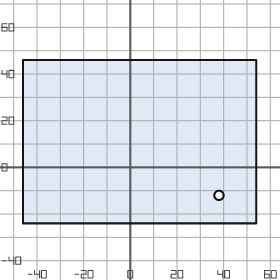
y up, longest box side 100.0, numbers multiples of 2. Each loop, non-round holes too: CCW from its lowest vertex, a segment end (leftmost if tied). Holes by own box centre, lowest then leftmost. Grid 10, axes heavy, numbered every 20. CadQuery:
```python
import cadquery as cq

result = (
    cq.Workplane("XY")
    .moveTo(-46.0, -24.0)
    .lineTo(54.0, -24.0)
    .lineTo(54.0, 46.0)
    .lineTo(-46.0, 46.0)
    .close()
    .moveTo(38.0, -12.0)
    .circle(2.0)
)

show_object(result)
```